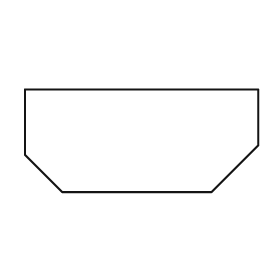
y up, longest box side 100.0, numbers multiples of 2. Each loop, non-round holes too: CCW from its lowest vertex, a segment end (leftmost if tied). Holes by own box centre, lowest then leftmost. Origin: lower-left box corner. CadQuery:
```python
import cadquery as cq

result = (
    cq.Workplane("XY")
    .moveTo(16.0, 0.0)
    .lineTo(80.0, 0.0)
    .lineTo(100.0, 20.0)
    .lineTo(100.0, 44.0)
    .lineTo(0.0, 44.0)
    .lineTo(0.0, 16.0)
    .close()
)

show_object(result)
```